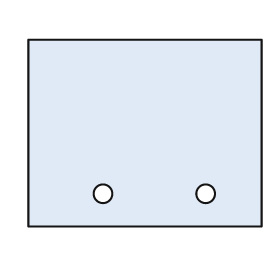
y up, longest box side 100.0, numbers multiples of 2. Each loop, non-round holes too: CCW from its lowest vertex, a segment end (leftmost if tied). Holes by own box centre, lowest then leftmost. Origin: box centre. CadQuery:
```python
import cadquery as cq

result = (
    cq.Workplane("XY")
    .moveTo(-50.0, -40.0)
    .lineTo(50.0, -40.0)
    .lineTo(50.0, 40.0)
    .lineTo(-50.0, 40.0)
    .close()
    .moveTo(-18.0, -26.0)
    .circle(4.0)
    .moveTo(26.0, -26.0)
    .circle(4.0)
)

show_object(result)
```